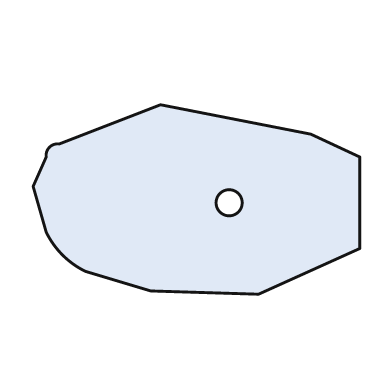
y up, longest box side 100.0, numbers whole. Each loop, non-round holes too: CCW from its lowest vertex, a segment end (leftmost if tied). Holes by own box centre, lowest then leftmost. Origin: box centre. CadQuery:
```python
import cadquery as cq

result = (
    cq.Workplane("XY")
    .moveTo(19.0, -29.0)
    .lineTo(50.0, -15.0)
    .lineTo(50.0, 13.0)
    .lineTo(35.0, 20.0)
    .lineTo(-11.0, 29.0)
    .lineTo(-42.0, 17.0)
    .threePointArc((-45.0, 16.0), (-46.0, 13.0))
    .lineTo(-50.0, 4.0)
    .lineTo(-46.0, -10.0)
    .threePointArc((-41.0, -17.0), (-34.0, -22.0))
    .lineTo(-14.0, -28.0)
    .close()
    .moveTo(10.0, -1.0)
    .circle(4.0)
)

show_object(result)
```